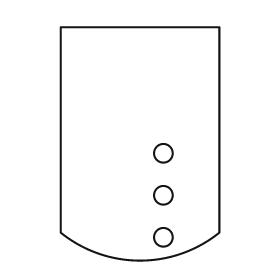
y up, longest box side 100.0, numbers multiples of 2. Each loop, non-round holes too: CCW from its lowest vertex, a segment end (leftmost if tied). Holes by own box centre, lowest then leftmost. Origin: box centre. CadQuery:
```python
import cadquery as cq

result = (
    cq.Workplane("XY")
    .moveTo(-34.0, -38.0)
    .threePointArc((0.0, -50.0), (34.0, -38.0))
    .lineTo(34.0, 50.0)
    .lineTo(-34.0, 50.0)
    .close()
    .moveTo(10.0, -40.0)
    .circle(4.0)
    .moveTo(10.0, -22.0)
    .circle(4.0)
    .moveTo(10.0, -4.0)
    .circle(4.0)
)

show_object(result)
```